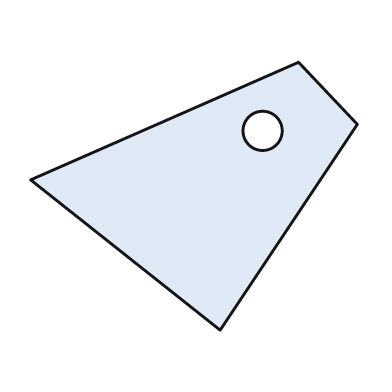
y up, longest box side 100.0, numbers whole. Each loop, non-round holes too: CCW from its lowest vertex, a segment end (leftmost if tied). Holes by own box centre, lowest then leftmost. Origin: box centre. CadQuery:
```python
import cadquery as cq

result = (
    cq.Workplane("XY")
    .moveTo(8.0, -41.0)
    .lineTo(50.0, 22.0)
    .lineTo(32.0, 41.0)
    .lineTo(-50.0, 5.0)
    .close()
    .moveTo(21.0, 20.0)
    .circle(6.0)
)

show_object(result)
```